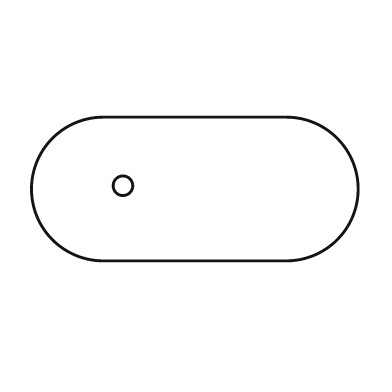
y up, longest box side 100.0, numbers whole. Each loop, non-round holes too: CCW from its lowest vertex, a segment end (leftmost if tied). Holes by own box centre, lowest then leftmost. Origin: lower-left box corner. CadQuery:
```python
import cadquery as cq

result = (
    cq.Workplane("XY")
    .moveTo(22.0, 0.0)
    .lineTo(78.0, 0.0)
    .threePointArc((100.0, 22.0), (78.0, 44.0))
    .lineTo(22.0, 44.0)
    .threePointArc((0.0, 22.0), (22.0, 0.0))
    .close()
    .moveTo(28.0, 23.0)
    .circle(3.0)
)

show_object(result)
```